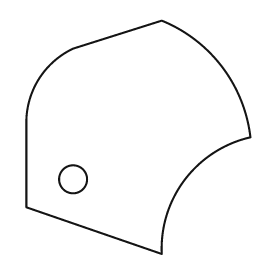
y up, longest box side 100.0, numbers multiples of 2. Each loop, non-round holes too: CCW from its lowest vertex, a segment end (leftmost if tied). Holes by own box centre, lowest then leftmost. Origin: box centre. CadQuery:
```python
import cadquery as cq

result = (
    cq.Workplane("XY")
    .moveTo(10.0, -50.0)
    .threePointArc((20.0, -18.0), (48.0, 0.0))
    .threePointArc((36.0, 30.0), (10.0, 50.0))
    .lineTo(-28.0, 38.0)
    .threePointArc((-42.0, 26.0), (-48.0, 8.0))
    .lineTo(-48.0, -30.0)
    .close()
    .moveTo(-28.0, -18.0)
    .circle(6.0)
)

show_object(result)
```